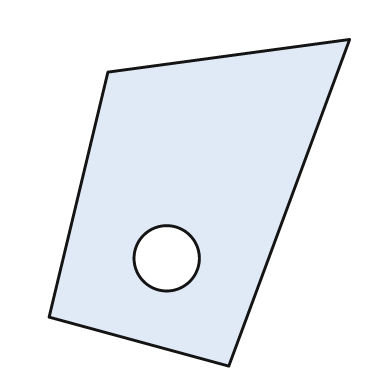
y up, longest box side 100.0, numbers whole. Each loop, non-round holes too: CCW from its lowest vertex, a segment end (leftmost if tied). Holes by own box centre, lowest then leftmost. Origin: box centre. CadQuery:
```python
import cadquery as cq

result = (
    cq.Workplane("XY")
    .moveTo(9.0, -50.0)
    .lineTo(46.0, 50.0)
    .lineTo(-28.0, 40.0)
    .lineTo(-46.0, -35.0)
    .close()
    .moveTo(-10.0, -17.0)
    .circle(10.0)
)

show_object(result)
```